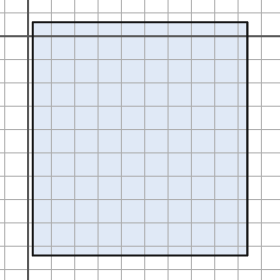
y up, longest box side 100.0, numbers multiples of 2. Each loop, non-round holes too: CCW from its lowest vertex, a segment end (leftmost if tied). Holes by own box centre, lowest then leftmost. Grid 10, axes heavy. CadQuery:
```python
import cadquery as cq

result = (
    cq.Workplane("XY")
    .moveTo(2.0, -94.0)
    .lineTo(94.0, -94.0)
    .lineTo(94.0, 6.0)
    .lineTo(2.0, 6.0)
    .close()
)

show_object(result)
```